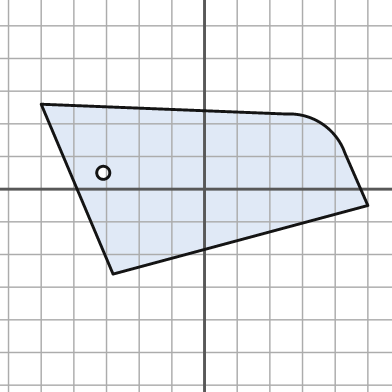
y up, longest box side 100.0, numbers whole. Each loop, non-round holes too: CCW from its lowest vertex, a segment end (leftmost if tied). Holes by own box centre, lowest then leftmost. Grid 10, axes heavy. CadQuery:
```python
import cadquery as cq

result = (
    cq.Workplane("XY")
    .moveTo(-28.0, -26.0)
    .lineTo(50.0, -5.0)
    .lineTo(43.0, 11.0)
    .threePointArc((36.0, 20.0), (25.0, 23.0))
    .lineTo(-50.0, 26.0)
    .close()
    .moveTo(-31.0, 5.0)
    .circle(2.0)
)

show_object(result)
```